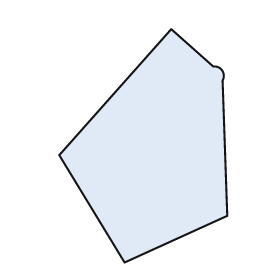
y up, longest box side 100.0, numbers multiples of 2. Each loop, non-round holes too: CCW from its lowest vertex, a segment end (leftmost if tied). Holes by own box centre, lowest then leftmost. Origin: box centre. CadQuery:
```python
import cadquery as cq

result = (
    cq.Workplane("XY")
    .moveTo(-8.0, -50.0)
    .lineTo(36.0, -30.0)
    .lineTo(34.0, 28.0)
    .threePointArc((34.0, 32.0), (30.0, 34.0))
    .lineTo(12.0, 50.0)
    .lineTo(-36.0, -4.0)
    .close()
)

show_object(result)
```